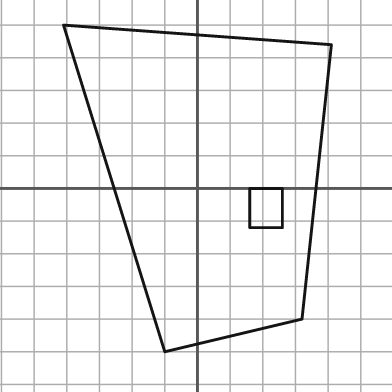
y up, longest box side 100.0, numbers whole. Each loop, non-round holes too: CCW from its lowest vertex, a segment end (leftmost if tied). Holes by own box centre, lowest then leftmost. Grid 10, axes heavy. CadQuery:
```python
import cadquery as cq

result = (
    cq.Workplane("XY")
    .moveTo(-10.0, -50.0)
    .lineTo(32.0, -40.0)
    .lineTo(41.0, 44.0)
    .lineTo(-41.0, 50.0)
    .close()
    .moveTo(16.0, -12.0)
    .lineTo(26.0, -12.0)
    .lineTo(26.0, 0.0)
    .lineTo(16.0, 0.0)
    .close()
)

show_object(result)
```